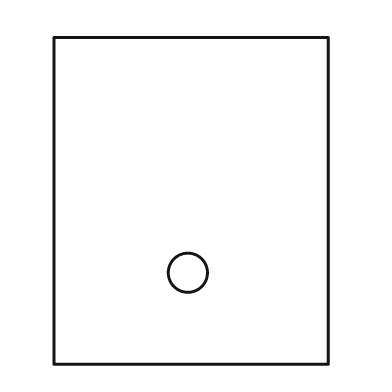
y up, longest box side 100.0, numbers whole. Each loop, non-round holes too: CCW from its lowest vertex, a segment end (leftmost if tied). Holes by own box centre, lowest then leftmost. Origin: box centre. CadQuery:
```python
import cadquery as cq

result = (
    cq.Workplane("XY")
    .moveTo(-42.0, -50.0)
    .lineTo(42.0, -50.0)
    .lineTo(42.0, 50.0)
    .lineTo(-42.0, 50.0)
    .close()
    .moveTo(-1.0, -22.0)
    .circle(6.0)
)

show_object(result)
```